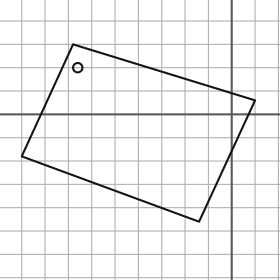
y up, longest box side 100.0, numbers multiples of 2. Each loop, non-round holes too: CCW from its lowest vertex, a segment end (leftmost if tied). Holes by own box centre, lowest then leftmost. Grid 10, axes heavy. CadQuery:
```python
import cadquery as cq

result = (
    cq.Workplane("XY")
    .moveTo(-14.0, -46.0)
    .lineTo(10.0, 6.0)
    .lineTo(-68.0, 30.0)
    .lineTo(-90.0, -18.0)
    .close()
    .moveTo(-66.0, 20.0)
    .circle(2.0)
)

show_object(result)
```